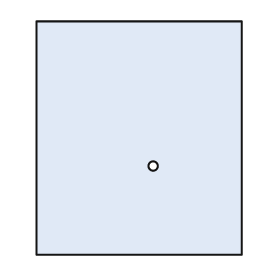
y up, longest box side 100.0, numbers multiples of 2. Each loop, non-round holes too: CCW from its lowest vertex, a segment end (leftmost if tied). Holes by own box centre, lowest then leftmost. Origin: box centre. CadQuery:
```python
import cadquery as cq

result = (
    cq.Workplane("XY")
    .moveTo(-44.0, -50.0)
    .lineTo(44.0, -50.0)
    .lineTo(44.0, 50.0)
    .lineTo(-44.0, 50.0)
    .close()
    .moveTo(6.0, -12.0)
    .circle(2.0)
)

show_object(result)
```